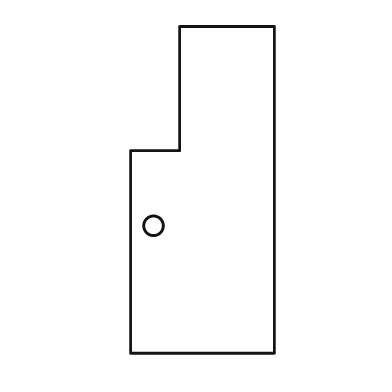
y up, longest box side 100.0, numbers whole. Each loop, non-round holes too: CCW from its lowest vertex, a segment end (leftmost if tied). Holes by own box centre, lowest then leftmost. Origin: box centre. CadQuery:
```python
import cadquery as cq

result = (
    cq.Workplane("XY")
    .moveTo(-22.0, -50.0)
    .lineTo(22.0, -50.0)
    .lineTo(22.0, 50.0)
    .lineTo(-7.0, 50.0)
    .lineTo(-7.0, 12.0)
    .lineTo(-22.0, 12.0)
    .close()
    .moveTo(-15.0, -11.0)
    .circle(3.0)
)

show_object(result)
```